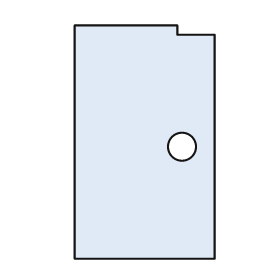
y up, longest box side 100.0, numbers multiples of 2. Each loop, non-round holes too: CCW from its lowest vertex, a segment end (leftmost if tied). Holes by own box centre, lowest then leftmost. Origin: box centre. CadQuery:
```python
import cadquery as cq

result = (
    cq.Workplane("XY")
    .moveTo(-30.0, -50.0)
    .lineTo(30.0, -50.0)
    .lineTo(30.0, 46.0)
    .lineTo(14.0, 46.0)
    .lineTo(14.0, 50.0)
    .lineTo(-30.0, 50.0)
    .close()
    .moveTo(16.0, -2.0)
    .circle(6.0)
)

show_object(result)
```